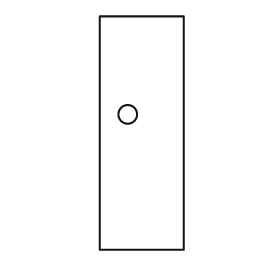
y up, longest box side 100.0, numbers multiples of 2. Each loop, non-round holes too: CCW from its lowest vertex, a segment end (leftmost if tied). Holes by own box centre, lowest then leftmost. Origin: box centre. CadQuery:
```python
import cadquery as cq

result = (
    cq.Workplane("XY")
    .moveTo(-18.0, -50.0)
    .lineTo(18.0, -50.0)
    .lineTo(18.0, 50.0)
    .lineTo(-18.0, 50.0)
    .close()
    .moveTo(-6.0, 8.0)
    .circle(4.0)
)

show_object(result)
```